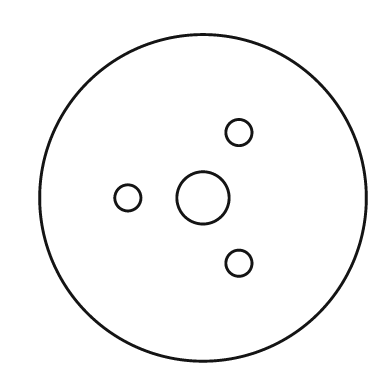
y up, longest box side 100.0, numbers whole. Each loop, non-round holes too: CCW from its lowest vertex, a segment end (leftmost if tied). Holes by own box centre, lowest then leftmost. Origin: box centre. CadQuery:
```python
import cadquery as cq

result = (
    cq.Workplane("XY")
    .moveTo(0.0, 0.0)
    .circle(50.0)
    .moveTo(11.0, -20.0)
    .circle(4.0)
    .moveTo(-23.0, 0.0)
    .circle(4.0)
    .moveTo(0.0, 0.0)
    .circle(8.0)
    .moveTo(11.0, 20.0)
    .circle(4.0)
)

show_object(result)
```